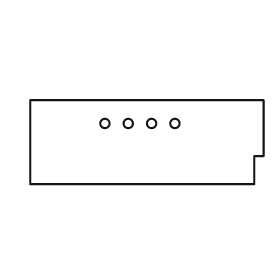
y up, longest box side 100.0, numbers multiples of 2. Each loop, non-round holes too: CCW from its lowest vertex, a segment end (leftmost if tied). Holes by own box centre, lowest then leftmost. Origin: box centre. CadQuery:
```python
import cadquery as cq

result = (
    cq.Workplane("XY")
    .moveTo(-50.0, -18.0)
    .lineTo(46.0, -18.0)
    .lineTo(46.0, -6.0)
    .lineTo(50.0, -6.0)
    .lineTo(50.0, 18.0)
    .lineTo(-50.0, 18.0)
    .close()
    .moveTo(-18.0, 8.0)
    .circle(2.0)
    .moveTo(-8.0, 8.0)
    .circle(2.0)
    .moveTo(2.0, 8.0)
    .circle(2.0)
    .moveTo(12.0, 8.0)
    .circle(2.0)
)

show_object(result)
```